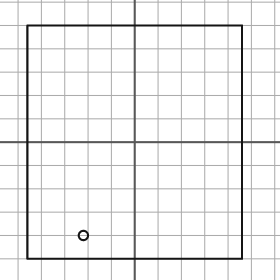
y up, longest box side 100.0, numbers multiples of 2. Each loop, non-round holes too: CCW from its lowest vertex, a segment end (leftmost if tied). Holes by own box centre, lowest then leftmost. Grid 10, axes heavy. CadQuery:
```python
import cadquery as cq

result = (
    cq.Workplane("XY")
    .moveTo(-46.0, -50.0)
    .lineTo(46.0, -50.0)
    .lineTo(46.0, 50.0)
    .lineTo(-46.0, 50.0)
    .close()
    .moveTo(-22.0, -40.0)
    .circle(2.0)
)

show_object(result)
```